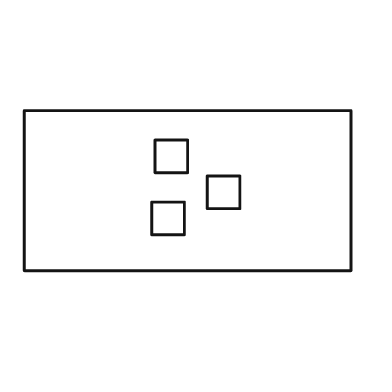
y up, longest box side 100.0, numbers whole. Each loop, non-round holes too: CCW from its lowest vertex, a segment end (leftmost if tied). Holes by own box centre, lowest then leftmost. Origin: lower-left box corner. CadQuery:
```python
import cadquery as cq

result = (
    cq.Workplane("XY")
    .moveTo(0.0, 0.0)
    .lineTo(100.0, 0.0)
    .lineTo(100.0, 49.0)
    .lineTo(0.0, 49.0)
    .close()
    .moveTo(39.0, 11.0)
    .lineTo(49.0, 11.0)
    .lineTo(49.0, 21.0)
    .lineTo(39.0, 21.0)
    .close()
    .moveTo(56.0, 19.0)
    .lineTo(66.0, 19.0)
    .lineTo(66.0, 29.0)
    .lineTo(56.0, 29.0)
    .close()
    .moveTo(40.0, 30.0)
    .lineTo(50.0, 30.0)
    .lineTo(50.0, 40.0)
    .lineTo(40.0, 40.0)
    .close()
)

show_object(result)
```